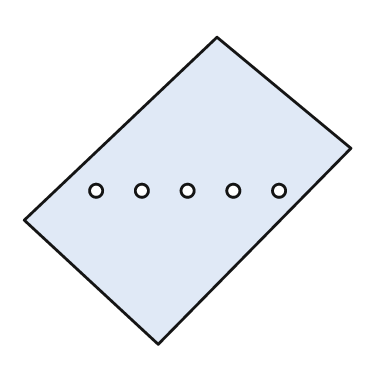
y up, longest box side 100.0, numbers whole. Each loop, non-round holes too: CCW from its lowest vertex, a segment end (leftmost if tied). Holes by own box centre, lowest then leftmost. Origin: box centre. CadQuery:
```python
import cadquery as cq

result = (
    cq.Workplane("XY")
    .moveTo(-9.0, -47.0)
    .lineTo(50.0, 13.0)
    .lineTo(9.0, 47.0)
    .lineTo(-50.0, -9.0)
    .close()
    .moveTo(-28.0, 0.0)
    .circle(2.0)
    .moveTo(-14.0, 0.0)
    .circle(2.0)
    .moveTo(0.0, 0.0)
    .circle(2.0)
    .moveTo(14.0, 0.0)
    .circle(2.0)
    .moveTo(28.0, 0.0)
    .circle(2.0)
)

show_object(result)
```